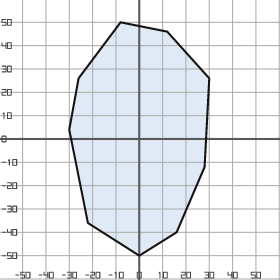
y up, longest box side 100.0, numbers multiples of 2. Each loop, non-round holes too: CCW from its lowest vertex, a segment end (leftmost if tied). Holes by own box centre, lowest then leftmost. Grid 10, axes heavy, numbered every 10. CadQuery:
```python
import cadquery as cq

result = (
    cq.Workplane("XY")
    .moveTo(0.0, -50.0)
    .lineTo(16.0, -40.0)
    .lineTo(28.0, -12.0)
    .lineTo(30.0, 26.0)
    .lineTo(12.0, 46.0)
    .lineTo(-8.0, 50.0)
    .lineTo(-26.0, 26.0)
    .lineTo(-30.0, 4.0)
    .lineTo(-22.0, -36.0)
    .close()
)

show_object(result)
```